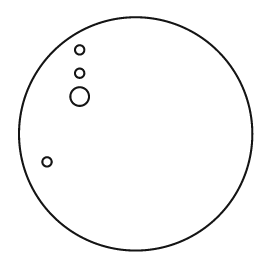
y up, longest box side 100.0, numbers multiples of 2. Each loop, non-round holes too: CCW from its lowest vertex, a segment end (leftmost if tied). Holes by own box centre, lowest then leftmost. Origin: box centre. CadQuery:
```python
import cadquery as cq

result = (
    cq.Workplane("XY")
    .moveTo(0.0, 0.0)
    .circle(50.0)
    .moveTo(-38.0, -12.0)
    .circle(2.0)
    .moveTo(-24.0, 16.0)
    .circle(4.0)
    .moveTo(-24.0, 26.0)
    .circle(2.0)
    .moveTo(-24.0, 36.0)
    .circle(2.0)
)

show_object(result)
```